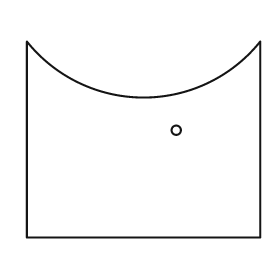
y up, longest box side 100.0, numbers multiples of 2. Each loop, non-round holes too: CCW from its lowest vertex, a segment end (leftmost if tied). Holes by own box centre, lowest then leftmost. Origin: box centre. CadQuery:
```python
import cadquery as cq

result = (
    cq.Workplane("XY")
    .moveTo(-50.0, -42.0)
    .lineTo(50.0, -42.0)
    .lineTo(50.0, 42.0)
    .threePointArc((0.0, 18.0), (-50.0, 42.0))
    .close()
    .moveTo(14.0, 4.0)
    .circle(2.0)
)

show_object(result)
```